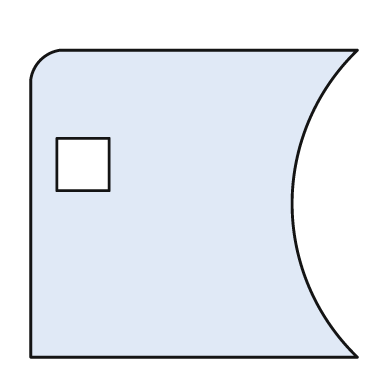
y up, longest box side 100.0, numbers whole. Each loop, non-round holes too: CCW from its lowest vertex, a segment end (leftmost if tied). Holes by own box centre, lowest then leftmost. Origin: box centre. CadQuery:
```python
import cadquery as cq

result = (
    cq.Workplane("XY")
    .moveTo(-50.0, -47.0)
    .lineTo(50.0, -47.0)
    .threePointArc((30.0, 0.0), (50.0, 47.0))
    .lineTo(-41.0, 47.0)
    .threePointArc((-47.0, 44.0), (-50.0, 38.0))
    .close()
    .moveTo(-42.0, 4.0)
    .lineTo(-26.0, 4.0)
    .lineTo(-26.0, 20.0)
    .lineTo(-42.0, 20.0)
    .close()
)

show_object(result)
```